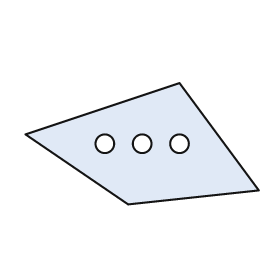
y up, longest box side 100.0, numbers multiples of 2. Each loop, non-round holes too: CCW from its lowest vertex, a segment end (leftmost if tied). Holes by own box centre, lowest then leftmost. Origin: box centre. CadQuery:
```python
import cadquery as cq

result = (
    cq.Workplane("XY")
    .moveTo(-6.0, -26.0)
    .lineTo(50.0, -20.0)
    .lineTo(16.0, 26.0)
    .lineTo(-50.0, 4.0)
    .close()
    .moveTo(-16.0, 0.0)
    .circle(4.0)
    .moveTo(0.0, 0.0)
    .circle(4.0)
    .moveTo(16.0, 0.0)
    .circle(4.0)
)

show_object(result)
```